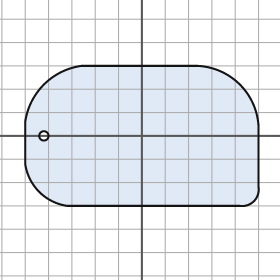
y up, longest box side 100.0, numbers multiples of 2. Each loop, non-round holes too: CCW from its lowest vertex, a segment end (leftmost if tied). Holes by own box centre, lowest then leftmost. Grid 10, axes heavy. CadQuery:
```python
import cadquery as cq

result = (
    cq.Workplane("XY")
    .moveTo(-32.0, -30.0)
    .lineTo(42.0, -30.0)
    .threePointArc((48.0, -28.0), (50.0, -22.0))
    .lineTo(50.0, 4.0)
    .threePointArc((42.0, 22.0), (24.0, 30.0))
    .lineTo(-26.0, 30.0)
    .threePointArc((-42.0, 22.0), (-50.0, 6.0))
    .lineTo(-50.0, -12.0)
    .threePointArc((-44.0, -24.0), (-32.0, -30.0))
    .close()
    .moveTo(-42.0, 0.0)
    .circle(2.0)
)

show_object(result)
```